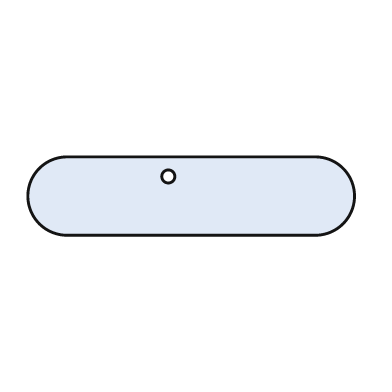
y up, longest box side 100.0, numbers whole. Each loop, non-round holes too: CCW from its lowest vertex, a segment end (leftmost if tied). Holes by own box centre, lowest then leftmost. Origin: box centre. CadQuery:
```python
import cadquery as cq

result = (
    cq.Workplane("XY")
    .moveTo(-38.0, -12.0)
    .lineTo(38.0, -12.0)
    .threePointArc((50.0, 0.0), (38.0, 12.0))
    .lineTo(-38.0, 12.0)
    .threePointArc((-50.0, 0.0), (-38.0, -12.0))
    .close()
    .moveTo(-7.0, 6.0)
    .circle(2.0)
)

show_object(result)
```